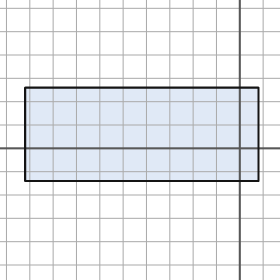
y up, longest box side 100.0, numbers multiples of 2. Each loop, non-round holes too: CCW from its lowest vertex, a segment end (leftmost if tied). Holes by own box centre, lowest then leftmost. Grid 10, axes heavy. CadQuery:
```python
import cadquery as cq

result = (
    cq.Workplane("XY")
    .moveTo(-92.0, -14.0)
    .lineTo(8.0, -14.0)
    .lineTo(8.0, 26.0)
    .lineTo(-92.0, 26.0)
    .close()
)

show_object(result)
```